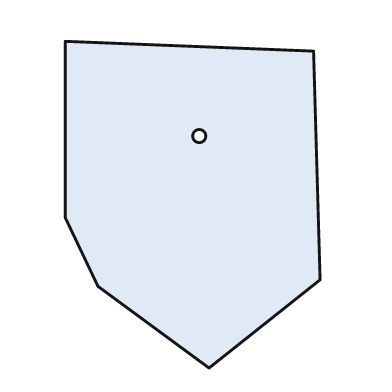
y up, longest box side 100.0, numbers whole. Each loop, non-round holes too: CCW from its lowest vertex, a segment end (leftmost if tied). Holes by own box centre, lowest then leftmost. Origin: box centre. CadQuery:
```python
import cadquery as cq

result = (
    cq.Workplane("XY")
    .moveTo(5.0, -50.0)
    .lineTo(39.0, -23.0)
    .lineTo(37.0, 47.0)
    .lineTo(-39.0, 50.0)
    .lineTo(-39.0, -4.0)
    .lineTo(-29.0, -25.0)
    .close()
    .moveTo(2.0, 21.0)
    .circle(2.0)
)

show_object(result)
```